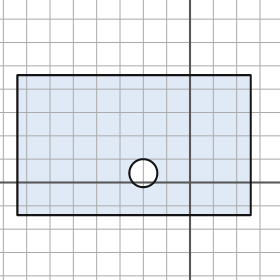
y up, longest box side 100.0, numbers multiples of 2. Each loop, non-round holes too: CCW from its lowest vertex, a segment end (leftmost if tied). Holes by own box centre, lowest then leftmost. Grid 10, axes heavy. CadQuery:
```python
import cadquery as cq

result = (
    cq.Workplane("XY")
    .moveTo(-74.0, -14.0)
    .lineTo(26.0, -14.0)
    .lineTo(26.0, 46.0)
    .lineTo(-74.0, 46.0)
    .close()
    .moveTo(-20.0, 4.0)
    .circle(6.0)
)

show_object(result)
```